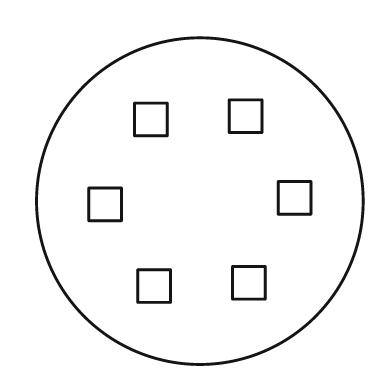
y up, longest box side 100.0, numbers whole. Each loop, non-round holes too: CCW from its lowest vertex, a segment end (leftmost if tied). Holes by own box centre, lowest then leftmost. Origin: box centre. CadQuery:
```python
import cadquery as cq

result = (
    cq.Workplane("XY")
    .moveTo(0.0, 0.0)
    .circle(50.0)
    .moveTo(-19.0, -31.0)
    .lineTo(-9.0, -31.0)
    .lineTo(-9.0, -21.0)
    .lineTo(-19.0, -21.0)
    .close()
    .moveTo(10.0, -30.0)
    .lineTo(20.0, -30.0)
    .lineTo(20.0, -20.0)
    .lineTo(10.0, -20.0)
    .close()
    .moveTo(-34.0, -6.0)
    .lineTo(-24.0, -6.0)
    .lineTo(-24.0, 4.0)
    .lineTo(-34.0, 4.0)
    .close()
    .moveTo(24.0, -4.0)
    .lineTo(34.0, -4.0)
    .lineTo(34.0, 6.0)
    .lineTo(24.0, 6.0)
    .close()
    .moveTo(-20.0, 20.0)
    .lineTo(-10.0, 20.0)
    .lineTo(-10.0, 30.0)
    .lineTo(-20.0, 30.0)
    .close()
    .moveTo(9.0, 21.0)
    .lineTo(19.0, 21.0)
    .lineTo(19.0, 31.0)
    .lineTo(9.0, 31.0)
    .close()
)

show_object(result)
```